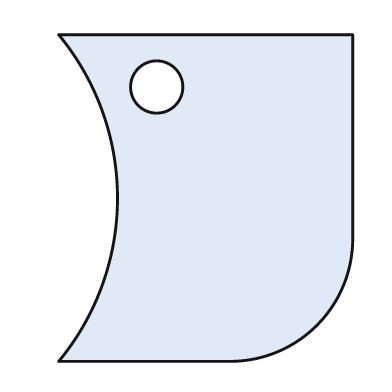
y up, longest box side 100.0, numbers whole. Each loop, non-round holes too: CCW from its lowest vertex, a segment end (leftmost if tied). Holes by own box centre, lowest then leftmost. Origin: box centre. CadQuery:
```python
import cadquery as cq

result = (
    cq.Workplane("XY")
    .moveTo(-45.0, -50.0)
    .lineTo(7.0, -50.0)
    .threePointArc((34.0, -39.0), (45.0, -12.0))
    .lineTo(45.0, 50.0)
    .lineTo(-45.0, 50.0)
    .threePointArc((-27.0, 0.0), (-45.0, -50.0))
    .close()
    .moveTo(-15.0, 34.0)
    .circle(8.0)
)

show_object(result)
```